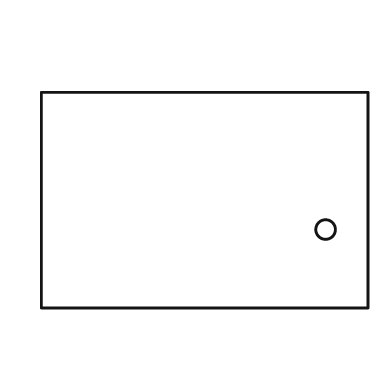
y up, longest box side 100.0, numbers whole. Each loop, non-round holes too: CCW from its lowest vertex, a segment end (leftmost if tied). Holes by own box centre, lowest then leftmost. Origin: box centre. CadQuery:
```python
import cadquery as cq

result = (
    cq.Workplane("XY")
    .moveTo(-50.0, -33.0)
    .lineTo(50.0, -33.0)
    .lineTo(50.0, 33.0)
    .lineTo(-50.0, 33.0)
    .close()
    .moveTo(37.0, -9.0)
    .circle(3.0)
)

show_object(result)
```